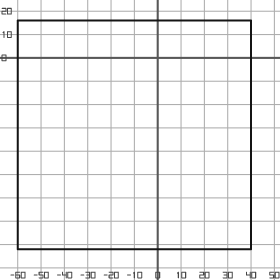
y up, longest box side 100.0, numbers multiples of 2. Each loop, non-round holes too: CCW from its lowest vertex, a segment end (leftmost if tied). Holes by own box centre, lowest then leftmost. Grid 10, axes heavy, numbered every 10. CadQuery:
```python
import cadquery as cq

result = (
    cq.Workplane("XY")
    .moveTo(-60.0, -82.0)
    .lineTo(40.0, -82.0)
    .lineTo(40.0, 16.0)
    .lineTo(-60.0, 16.0)
    .close()
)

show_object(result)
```